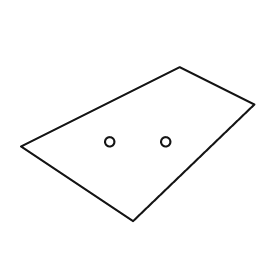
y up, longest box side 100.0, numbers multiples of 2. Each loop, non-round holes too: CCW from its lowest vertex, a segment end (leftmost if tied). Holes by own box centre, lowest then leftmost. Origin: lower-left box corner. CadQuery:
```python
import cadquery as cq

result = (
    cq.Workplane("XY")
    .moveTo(48.0, 0.0)
    .lineTo(100.0, 50.0)
    .lineTo(68.0, 66.0)
    .lineTo(0.0, 32.0)
    .close()
    .moveTo(38.0, 34.0)
    .circle(2.0)
    .moveTo(62.0, 34.0)
    .circle(2.0)
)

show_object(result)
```